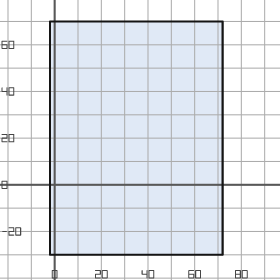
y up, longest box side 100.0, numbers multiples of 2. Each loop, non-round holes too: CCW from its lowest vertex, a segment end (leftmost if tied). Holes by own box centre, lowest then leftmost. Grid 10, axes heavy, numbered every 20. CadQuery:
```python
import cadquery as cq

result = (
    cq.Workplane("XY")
    .moveTo(-2.0, -30.0)
    .lineTo(72.0, -30.0)
    .lineTo(72.0, 70.0)
    .lineTo(-2.0, 70.0)
    .close()
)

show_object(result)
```